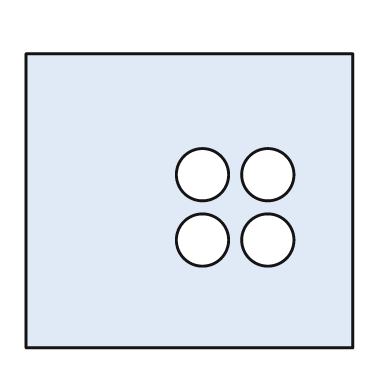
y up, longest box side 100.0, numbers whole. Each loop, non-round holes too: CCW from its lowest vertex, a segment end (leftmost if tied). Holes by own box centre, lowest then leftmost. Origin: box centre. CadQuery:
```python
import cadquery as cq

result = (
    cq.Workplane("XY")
    .moveTo(-50.0, -45.0)
    .lineTo(50.0, -45.0)
    .lineTo(50.0, 45.0)
    .lineTo(-50.0, 45.0)
    .close()
    .moveTo(4.0, -12.0)
    .circle(8.0)
    .moveTo(24.0, -12.0)
    .circle(8.0)
    .moveTo(4.0, 8.0)
    .circle(8.0)
    .moveTo(24.0, 8.0)
    .circle(8.0)
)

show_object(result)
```